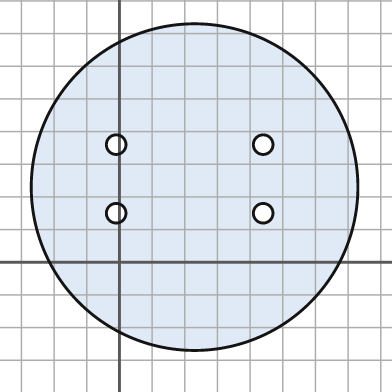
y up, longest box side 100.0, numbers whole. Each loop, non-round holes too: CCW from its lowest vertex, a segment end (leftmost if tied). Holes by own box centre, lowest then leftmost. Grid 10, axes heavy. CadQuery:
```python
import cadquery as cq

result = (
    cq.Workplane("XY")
    .moveTo(23.0, 23.0)
    .circle(50.0)
    .moveTo(-1.0, 15.0)
    .circle(3.0)
    .moveTo(44.0, 15.0)
    .circle(3.0)
    .moveTo(-1.0, 36.0)
    .circle(3.0)
    .moveTo(44.0, 36.0)
    .circle(3.0)
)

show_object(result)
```